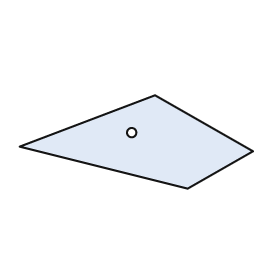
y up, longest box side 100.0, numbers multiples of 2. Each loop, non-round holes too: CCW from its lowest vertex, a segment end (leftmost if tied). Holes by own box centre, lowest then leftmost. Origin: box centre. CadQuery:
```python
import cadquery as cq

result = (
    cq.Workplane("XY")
    .moveTo(22.0, -20.0)
    .lineTo(50.0, -4.0)
    .lineTo(8.0, 20.0)
    .lineTo(-50.0, -2.0)
    .close()
    .moveTo(-2.0, 4.0)
    .circle(2.0)
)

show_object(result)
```